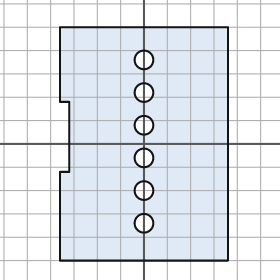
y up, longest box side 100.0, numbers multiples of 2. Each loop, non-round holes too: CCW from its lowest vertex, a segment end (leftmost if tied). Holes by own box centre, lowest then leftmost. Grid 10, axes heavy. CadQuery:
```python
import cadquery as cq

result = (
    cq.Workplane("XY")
    .moveTo(-36.0, -50.0)
    .lineTo(36.0, -50.0)
    .lineTo(36.0, 50.0)
    .lineTo(-36.0, 50.0)
    .lineTo(-36.0, 18.0)
    .lineTo(-32.0, 18.0)
    .lineTo(-32.0, -12.0)
    .lineTo(-36.0, -12.0)
    .close()
    .moveTo(0.0, -34.0)
    .circle(4.0)
    .moveTo(0.0, -20.0)
    .circle(4.0)
    .moveTo(0.0, -6.0)
    .circle(4.0)
    .moveTo(0.0, 8.0)
    .circle(4.0)
    .moveTo(0.0, 22.0)
    .circle(4.0)
    .moveTo(0.0, 36.0)
    .circle(4.0)
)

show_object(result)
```